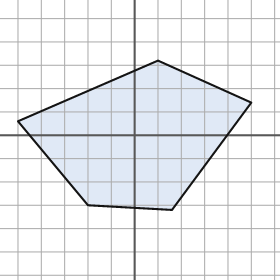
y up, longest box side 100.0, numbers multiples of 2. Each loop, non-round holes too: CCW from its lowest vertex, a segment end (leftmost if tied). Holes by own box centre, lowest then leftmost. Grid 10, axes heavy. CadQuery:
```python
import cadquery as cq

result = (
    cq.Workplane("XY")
    .moveTo(16.0, -32.0)
    .lineTo(50.0, 14.0)
    .lineTo(10.0, 32.0)
    .lineTo(-50.0, 6.0)
    .lineTo(-20.0, -30.0)
    .close()
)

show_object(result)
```